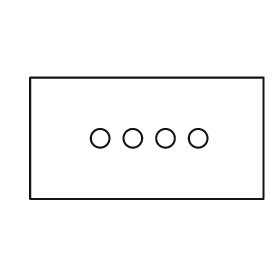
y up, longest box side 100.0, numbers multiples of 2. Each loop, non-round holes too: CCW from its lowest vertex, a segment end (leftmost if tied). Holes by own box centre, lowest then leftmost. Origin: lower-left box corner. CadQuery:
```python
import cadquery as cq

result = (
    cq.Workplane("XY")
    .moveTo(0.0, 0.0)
    .lineTo(100.0, 0.0)
    .lineTo(100.0, 52.0)
    .lineTo(0.0, 52.0)
    .close()
    .moveTo(30.0, 26.0)
    .circle(4.0)
    .moveTo(44.0, 26.0)
    .circle(4.0)
    .moveTo(58.0, 26.0)
    .circle(4.0)
    .moveTo(72.0, 26.0)
    .circle(4.0)
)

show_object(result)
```